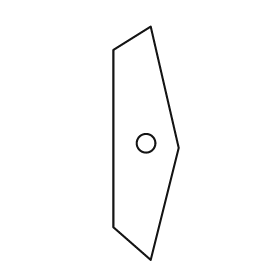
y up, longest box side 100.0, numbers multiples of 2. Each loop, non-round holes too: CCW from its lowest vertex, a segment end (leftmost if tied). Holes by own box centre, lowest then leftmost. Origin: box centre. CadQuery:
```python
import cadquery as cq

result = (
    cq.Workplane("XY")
    .moveTo(2.0, -50.0)
    .lineTo(14.0, -2.0)
    .lineTo(2.0, 50.0)
    .lineTo(-14.0, 40.0)
    .lineTo(-14.0, -36.0)
    .close()
    .moveTo(0.0, 0.0)
    .circle(4.0)
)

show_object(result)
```